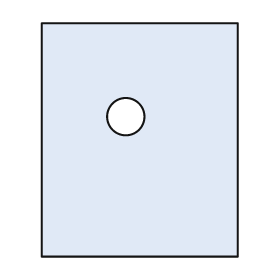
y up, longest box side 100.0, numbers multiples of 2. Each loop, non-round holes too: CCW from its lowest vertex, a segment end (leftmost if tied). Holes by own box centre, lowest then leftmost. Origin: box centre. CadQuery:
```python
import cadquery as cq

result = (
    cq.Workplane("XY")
    .moveTo(-42.0, -50.0)
    .lineTo(42.0, -50.0)
    .lineTo(42.0, 50.0)
    .lineTo(-42.0, 50.0)
    .close()
    .moveTo(-6.0, 10.0)
    .circle(8.0)
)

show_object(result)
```